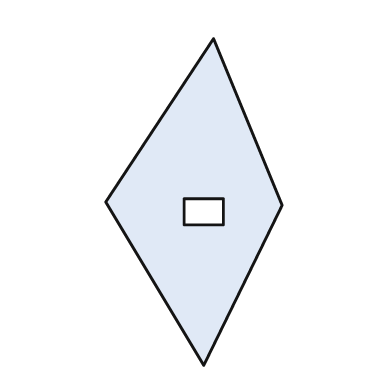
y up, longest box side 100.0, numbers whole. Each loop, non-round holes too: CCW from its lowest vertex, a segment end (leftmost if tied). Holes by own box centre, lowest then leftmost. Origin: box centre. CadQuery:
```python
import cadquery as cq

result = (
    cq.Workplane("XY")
    .moveTo(3.0, -50.0)
    .lineTo(27.0, -1.0)
    .lineTo(6.0, 50.0)
    .lineTo(-27.0, 0.0)
    .close()
    .moveTo(-3.0, -7.0)
    .lineTo(9.0, -7.0)
    .lineTo(9.0, 1.0)
    .lineTo(-3.0, 1.0)
    .close()
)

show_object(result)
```